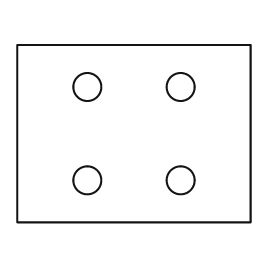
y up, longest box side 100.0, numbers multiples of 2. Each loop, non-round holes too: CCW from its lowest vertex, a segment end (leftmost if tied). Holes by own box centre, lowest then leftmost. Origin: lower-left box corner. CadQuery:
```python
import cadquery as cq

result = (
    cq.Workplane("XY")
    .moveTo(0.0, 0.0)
    .lineTo(100.0, 0.0)
    .lineTo(100.0, 76.0)
    .lineTo(0.0, 76.0)
    .close()
    .moveTo(30.0, 18.0)
    .circle(6.0)
    .moveTo(70.0, 18.0)
    .circle(6.0)
    .moveTo(30.0, 58.0)
    .circle(6.0)
    .moveTo(70.0, 58.0)
    .circle(6.0)
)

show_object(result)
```